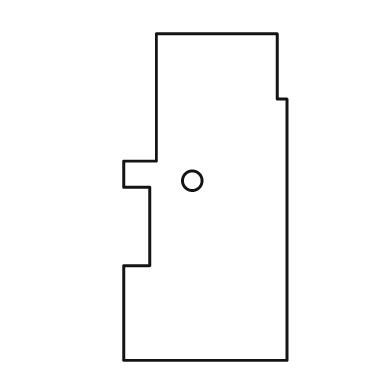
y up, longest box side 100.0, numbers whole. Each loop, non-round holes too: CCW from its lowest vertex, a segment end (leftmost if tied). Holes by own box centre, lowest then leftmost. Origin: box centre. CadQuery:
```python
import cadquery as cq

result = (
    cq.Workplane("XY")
    .moveTo(-25.0, -50.0)
    .lineTo(25.0, -50.0)
    .lineTo(25.0, 30.0)
    .lineTo(22.0, 30.0)
    .lineTo(22.0, 50.0)
    .lineTo(-15.0, 50.0)
    .lineTo(-15.0, 11.0)
    .lineTo(-25.0, 11.0)
    .lineTo(-25.0, 3.0)
    .lineTo(-17.0, 3.0)
    .lineTo(-17.0, -21.0)
    .lineTo(-25.0, -21.0)
    .close()
    .moveTo(-4.0, 5.0)
    .circle(3.0)
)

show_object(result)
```